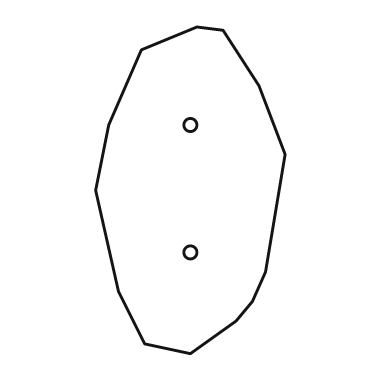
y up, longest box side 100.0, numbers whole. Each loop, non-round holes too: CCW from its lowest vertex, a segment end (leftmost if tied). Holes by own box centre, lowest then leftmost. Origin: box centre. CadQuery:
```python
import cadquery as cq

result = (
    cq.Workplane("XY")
    .moveTo(0.0, -50.0)
    .lineTo(14.0, -40.0)
    .lineTo(19.0, -34.0)
    .lineTo(23.0, -25.0)
    .lineTo(29.0, 11.0)
    .lineTo(21.0, 32.0)
    .lineTo(10.0, 49.0)
    .lineTo(2.0, 50.0)
    .lineTo(-15.0, 43.0)
    .lineTo(-25.0, 20.0)
    .lineTo(-29.0, 0.0)
    .lineTo(-22.0, -31.0)
    .lineTo(-14.0, -47.0)
    .close()
    .moveTo(0.0, -19.0)
    .circle(2.0)
    .moveTo(0.0, 20.0)
    .circle(2.0)
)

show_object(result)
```